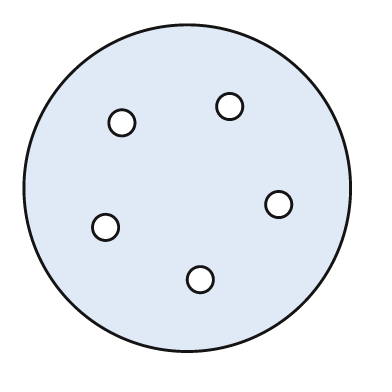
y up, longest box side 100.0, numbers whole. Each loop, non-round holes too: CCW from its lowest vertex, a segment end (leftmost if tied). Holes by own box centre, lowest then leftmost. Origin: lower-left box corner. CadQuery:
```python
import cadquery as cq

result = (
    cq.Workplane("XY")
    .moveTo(50.0, 50.0)
    .circle(50.0)
    .moveTo(54.0, 22.0)
    .circle(4.0)
    .moveTo(25.0, 38.0)
    .circle(4.0)
    .moveTo(78.0, 45.0)
    .circle(4.0)
    .moveTo(30.0, 70.0)
    .circle(4.0)
    .moveTo(63.0, 75.0)
    .circle(4.0)
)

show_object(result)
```